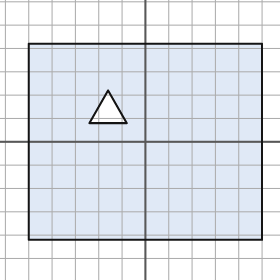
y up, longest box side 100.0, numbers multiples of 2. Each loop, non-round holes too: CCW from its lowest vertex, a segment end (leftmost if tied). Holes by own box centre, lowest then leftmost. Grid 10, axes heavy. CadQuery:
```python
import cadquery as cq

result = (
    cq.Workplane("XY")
    .moveTo(-50.0, -42.0)
    .lineTo(50.0, -42.0)
    .lineTo(50.0, 42.0)
    .lineTo(-50.0, 42.0)
    .close()
    .moveTo(-24.0, 8.0)
    .lineTo(-8.0, 8.0)
    .lineTo(-16.0, 22.0)
    .close()
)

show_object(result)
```